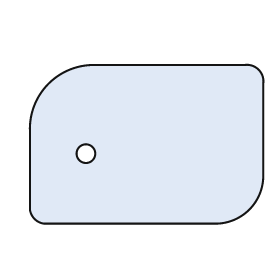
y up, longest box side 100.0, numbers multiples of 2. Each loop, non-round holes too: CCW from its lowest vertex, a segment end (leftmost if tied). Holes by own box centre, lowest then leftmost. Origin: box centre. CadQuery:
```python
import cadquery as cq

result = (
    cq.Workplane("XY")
    .moveTo(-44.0, -34.0)
    .lineTo(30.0, -34.0)
    .threePointArc((44.0, -28.0), (50.0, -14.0))
    .lineTo(50.0, 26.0)
    .threePointArc((48.0, 32.0), (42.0, 34.0))
    .lineTo(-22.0, 34.0)
    .threePointArc((-42.0, 26.0), (-50.0, 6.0))
    .lineTo(-50.0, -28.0)
    .threePointArc((-48.0, -32.0), (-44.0, -34.0))
    .close()
    .moveTo(-26.0, -4.0)
    .circle(4.0)
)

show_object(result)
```